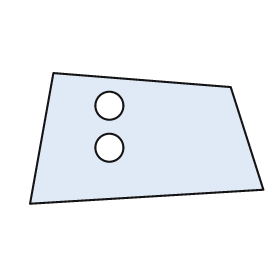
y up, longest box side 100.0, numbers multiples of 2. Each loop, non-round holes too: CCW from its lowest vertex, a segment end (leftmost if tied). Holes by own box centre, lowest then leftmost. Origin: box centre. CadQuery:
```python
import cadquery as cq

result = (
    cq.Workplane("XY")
    .moveTo(-50.0, -28.0)
    .lineTo(50.0, -22.0)
    .lineTo(36.0, 22.0)
    .lineTo(-40.0, 28.0)
    .close()
    .moveTo(-16.0, -4.0)
    .circle(6.0)
    .moveTo(-16.0, 14.0)
    .circle(6.0)
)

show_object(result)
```